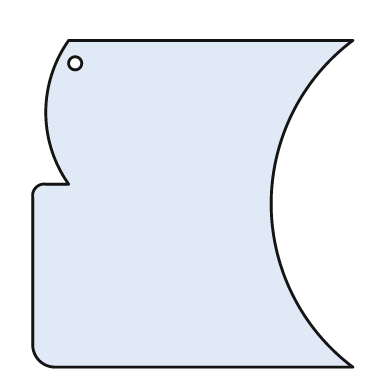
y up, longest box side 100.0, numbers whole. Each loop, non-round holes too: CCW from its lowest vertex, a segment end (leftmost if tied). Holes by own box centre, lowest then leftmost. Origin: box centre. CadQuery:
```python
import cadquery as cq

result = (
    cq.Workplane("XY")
    .moveTo(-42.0, -50.0)
    .lineTo(49.0, -50.0)
    .threePointArc((24.0, 0.0), (49.0, 50.0))
    .lineTo(-38.0, 50.0)
    .threePointArc((-45.0, 28.0), (-38.0, 6.0))
    .lineTo(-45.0, 6.0)
    .threePointArc((-48.0, 5.0), (-49.0, 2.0))
    .lineTo(-49.0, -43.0)
    .threePointArc((-47.0, -48.0), (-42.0, -50.0))
    .close()
    .moveTo(-36.0, 43.0)
    .circle(2.0)
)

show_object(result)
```